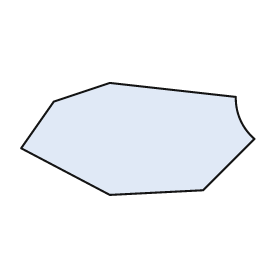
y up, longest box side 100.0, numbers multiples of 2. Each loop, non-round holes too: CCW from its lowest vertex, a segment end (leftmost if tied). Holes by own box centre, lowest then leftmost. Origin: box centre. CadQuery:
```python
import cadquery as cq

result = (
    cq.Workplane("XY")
    .moveTo(-12.0, -24.0)
    .lineTo(28.0, -22.0)
    .lineTo(50.0, 0.0)
    .threePointArc((44.0, 8.0), (42.0, 18.0))
    .lineTo(-12.0, 24.0)
    .lineTo(-36.0, 16.0)
    .lineTo(-50.0, -4.0)
    .close()
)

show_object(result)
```